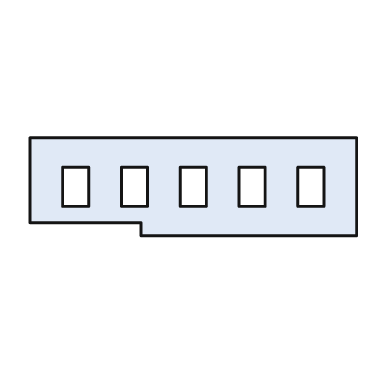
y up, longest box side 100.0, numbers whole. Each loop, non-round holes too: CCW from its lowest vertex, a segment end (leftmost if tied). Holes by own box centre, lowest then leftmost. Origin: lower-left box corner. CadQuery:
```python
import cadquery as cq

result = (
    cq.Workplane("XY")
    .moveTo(34.0, 0.0)
    .lineTo(100.0, 0.0)
    .lineTo(100.0, 30.0)
    .lineTo(0.0, 30.0)
    .lineTo(0.0, 4.0)
    .lineTo(34.0, 4.0)
    .close()
    .moveTo(10.0, 9.0)
    .lineTo(18.0, 9.0)
    .lineTo(18.0, 21.0)
    .lineTo(10.0, 21.0)
    .close()
    .moveTo(28.0, 9.0)
    .lineTo(36.0, 9.0)
    .lineTo(36.0, 21.0)
    .lineTo(28.0, 21.0)
    .close()
    .moveTo(46.0, 9.0)
    .lineTo(54.0, 9.0)
    .lineTo(54.0, 21.0)
    .lineTo(46.0, 21.0)
    .close()
    .moveTo(64.0, 9.0)
    .lineTo(72.0, 9.0)
    .lineTo(72.0, 21.0)
    .lineTo(64.0, 21.0)
    .close()
    .moveTo(82.0, 9.0)
    .lineTo(90.0, 9.0)
    .lineTo(90.0, 21.0)
    .lineTo(82.0, 21.0)
    .close()
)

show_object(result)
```